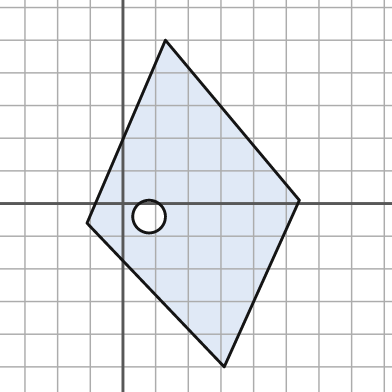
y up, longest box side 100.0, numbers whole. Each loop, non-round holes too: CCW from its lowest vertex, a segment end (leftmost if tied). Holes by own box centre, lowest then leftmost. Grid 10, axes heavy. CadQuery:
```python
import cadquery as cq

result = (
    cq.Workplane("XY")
    .moveTo(31.0, -50.0)
    .lineTo(54.0, 1.0)
    .lineTo(13.0, 50.0)
    .lineTo(-11.0, -6.0)
    .close()
    .moveTo(8.0, -4.0)
    .circle(5.0)
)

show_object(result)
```